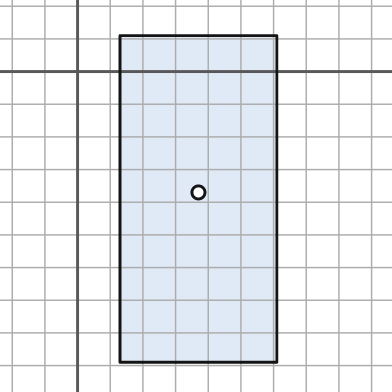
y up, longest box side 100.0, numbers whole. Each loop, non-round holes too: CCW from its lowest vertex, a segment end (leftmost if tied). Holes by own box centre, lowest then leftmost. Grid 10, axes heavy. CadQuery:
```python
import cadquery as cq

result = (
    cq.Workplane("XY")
    .moveTo(13.0, -89.0)
    .lineTo(61.0, -89.0)
    .lineTo(61.0, 11.0)
    .lineTo(13.0, 11.0)
    .close()
    .moveTo(37.0, -37.0)
    .circle(2.0)
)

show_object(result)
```